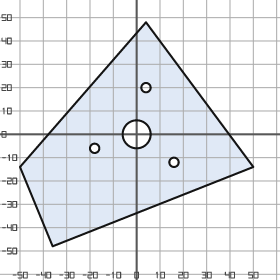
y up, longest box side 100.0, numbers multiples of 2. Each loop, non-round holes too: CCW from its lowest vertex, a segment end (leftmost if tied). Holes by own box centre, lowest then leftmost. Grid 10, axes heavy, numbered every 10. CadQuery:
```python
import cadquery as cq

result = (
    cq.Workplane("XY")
    .moveTo(-36.0, -48.0)
    .lineTo(50.0, -14.0)
    .lineTo(4.0, 48.0)
    .lineTo(-50.0, -14.0)
    .close()
    .moveTo(16.0, -12.0)
    .circle(2.0)
    .moveTo(-18.0, -6.0)
    .circle(2.0)
    .moveTo(0.0, 0.0)
    .circle(6.0)
    .moveTo(4.0, 20.0)
    .circle(2.0)
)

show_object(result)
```